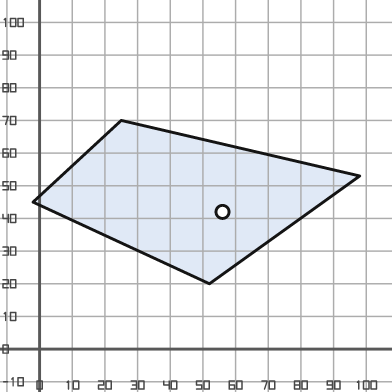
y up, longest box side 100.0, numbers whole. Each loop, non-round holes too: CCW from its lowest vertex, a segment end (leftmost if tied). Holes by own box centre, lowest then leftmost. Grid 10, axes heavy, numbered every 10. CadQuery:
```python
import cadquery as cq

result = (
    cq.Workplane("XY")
    .moveTo(52.0, 20.0)
    .lineTo(98.0, 53.0)
    .lineTo(25.0, 70.0)
    .lineTo(-2.0, 45.0)
    .close()
    .moveTo(56.0, 42.0)
    .circle(2.0)
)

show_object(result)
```